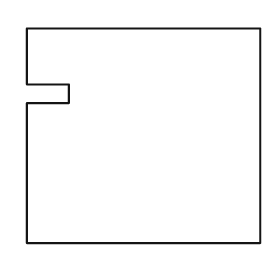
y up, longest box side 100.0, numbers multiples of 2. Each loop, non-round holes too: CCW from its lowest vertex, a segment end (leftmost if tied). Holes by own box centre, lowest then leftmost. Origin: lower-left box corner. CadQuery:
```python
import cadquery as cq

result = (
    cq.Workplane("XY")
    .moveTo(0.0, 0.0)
    .lineTo(100.0, 0.0)
    .lineTo(100.0, 92.0)
    .lineTo(0.0, 92.0)
    .lineTo(0.0, 68.0)
    .lineTo(18.0, 68.0)
    .lineTo(18.0, 60.0)
    .lineTo(0.0, 60.0)
    .close()
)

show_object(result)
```